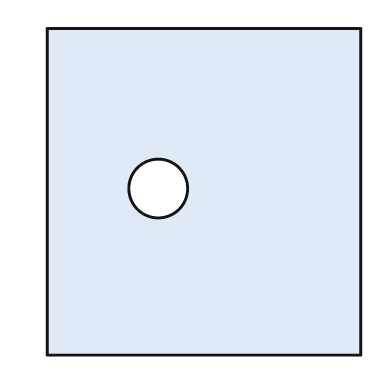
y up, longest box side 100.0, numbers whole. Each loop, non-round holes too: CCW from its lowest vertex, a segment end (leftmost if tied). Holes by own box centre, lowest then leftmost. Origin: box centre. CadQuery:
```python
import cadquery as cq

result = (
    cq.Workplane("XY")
    .moveTo(-48.0, -50.0)
    .lineTo(48.0, -50.0)
    .lineTo(48.0, 50.0)
    .lineTo(-48.0, 50.0)
    .close()
    .moveTo(-14.0, 1.0)
    .circle(9.0)
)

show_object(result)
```